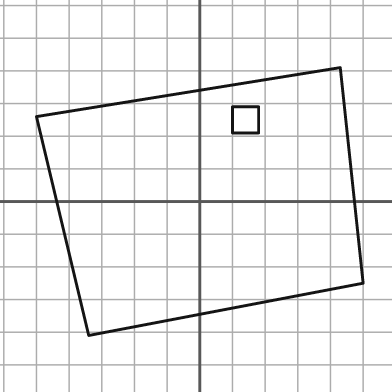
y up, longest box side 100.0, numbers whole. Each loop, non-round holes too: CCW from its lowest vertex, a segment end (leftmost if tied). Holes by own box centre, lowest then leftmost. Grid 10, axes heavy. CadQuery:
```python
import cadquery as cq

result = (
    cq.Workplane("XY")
    .moveTo(-34.0, -41.0)
    .lineTo(50.0, -25.0)
    .lineTo(43.0, 41.0)
    .lineTo(-50.0, 26.0)
    .close()
    .moveTo(10.0, 21.0)
    .lineTo(18.0, 21.0)
    .lineTo(18.0, 29.0)
    .lineTo(10.0, 29.0)
    .close()
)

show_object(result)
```